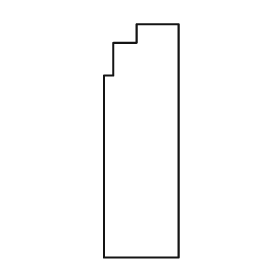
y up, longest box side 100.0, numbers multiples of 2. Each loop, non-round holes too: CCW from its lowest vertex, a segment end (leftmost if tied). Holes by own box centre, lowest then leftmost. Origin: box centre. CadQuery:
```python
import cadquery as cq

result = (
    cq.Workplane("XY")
    .moveTo(-16.0, -50.0)
    .lineTo(16.0, -50.0)
    .lineTo(16.0, 50.0)
    .lineTo(-2.0, 50.0)
    .lineTo(-2.0, 42.0)
    .lineTo(-12.0, 42.0)
    .lineTo(-12.0, 28.0)
    .lineTo(-16.0, 28.0)
    .close()
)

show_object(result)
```